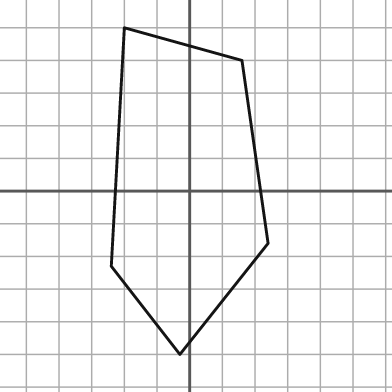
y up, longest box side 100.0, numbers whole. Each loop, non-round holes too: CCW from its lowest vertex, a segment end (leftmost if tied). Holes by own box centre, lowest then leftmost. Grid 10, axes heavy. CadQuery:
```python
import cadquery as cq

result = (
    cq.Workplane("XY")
    .moveTo(-3.0, -50.0)
    .lineTo(24.0, -16.0)
    .lineTo(16.0, 40.0)
    .lineTo(-20.0, 50.0)
    .lineTo(-24.0, -23.0)
    .close()
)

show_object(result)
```